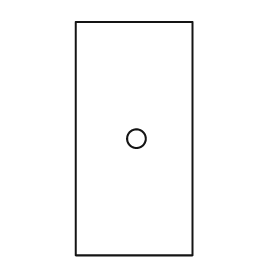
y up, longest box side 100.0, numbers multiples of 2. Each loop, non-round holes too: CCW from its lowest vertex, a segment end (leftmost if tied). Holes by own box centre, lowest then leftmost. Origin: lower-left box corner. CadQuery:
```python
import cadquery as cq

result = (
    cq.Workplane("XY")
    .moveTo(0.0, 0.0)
    .lineTo(50.0, 0.0)
    .lineTo(50.0, 100.0)
    .lineTo(0.0, 100.0)
    .close()
    .moveTo(26.0, 50.0)
    .circle(4.0)
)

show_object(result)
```